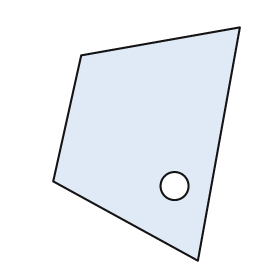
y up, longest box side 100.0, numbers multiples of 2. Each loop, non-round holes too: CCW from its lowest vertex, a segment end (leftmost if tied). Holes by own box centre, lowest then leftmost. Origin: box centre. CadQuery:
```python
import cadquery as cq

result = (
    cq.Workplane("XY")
    .moveTo(22.0, -50.0)
    .lineTo(40.0, 50.0)
    .lineTo(-28.0, 38.0)
    .lineTo(-40.0, -16.0)
    .close()
    .moveTo(12.0, -18.0)
    .circle(6.0)
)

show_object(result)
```